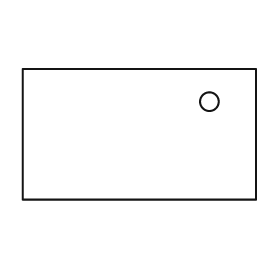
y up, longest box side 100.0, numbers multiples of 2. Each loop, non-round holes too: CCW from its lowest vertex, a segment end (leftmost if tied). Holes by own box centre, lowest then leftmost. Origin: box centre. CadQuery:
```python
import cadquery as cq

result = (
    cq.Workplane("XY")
    .moveTo(-50.0, -28.0)
    .lineTo(50.0, -28.0)
    .lineTo(50.0, 28.0)
    .lineTo(-50.0, 28.0)
    .close()
    .moveTo(30.0, 14.0)
    .circle(4.0)
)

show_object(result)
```